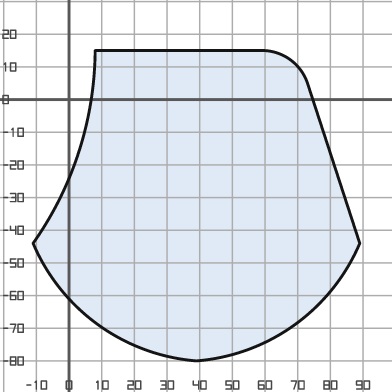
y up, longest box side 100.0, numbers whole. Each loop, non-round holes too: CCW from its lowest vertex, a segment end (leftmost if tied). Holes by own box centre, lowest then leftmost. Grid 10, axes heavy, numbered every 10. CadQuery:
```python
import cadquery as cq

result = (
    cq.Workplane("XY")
    .moveTo(39.0, -80.0)
    .threePointArc((69.0, -69.0), (89.0, -44.0))
    .lineTo(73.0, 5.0)
    .threePointArc((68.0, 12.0), (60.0, 15.0))
    .lineTo(8.0, 15.0)
    .threePointArc((3.0, -16.0), (-11.0, -44.0))
    .threePointArc((9.0, -69.0), (39.0, -80.0))
    .close()
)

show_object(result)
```